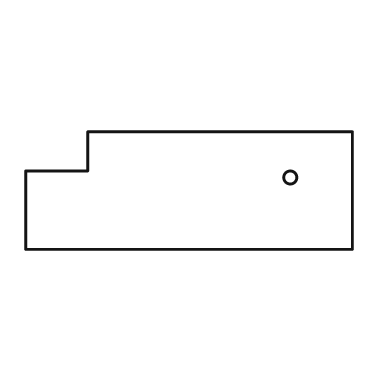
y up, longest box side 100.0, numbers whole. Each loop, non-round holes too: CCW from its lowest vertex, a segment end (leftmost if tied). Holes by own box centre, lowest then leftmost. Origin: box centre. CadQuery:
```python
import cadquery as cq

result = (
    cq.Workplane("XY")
    .moveTo(-50.0, -18.0)
    .lineTo(50.0, -18.0)
    .lineTo(50.0, 18.0)
    .lineTo(-31.0, 18.0)
    .lineTo(-31.0, 6.0)
    .lineTo(-50.0, 6.0)
    .close()
    .moveTo(31.0, 4.0)
    .circle(2.0)
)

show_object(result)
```